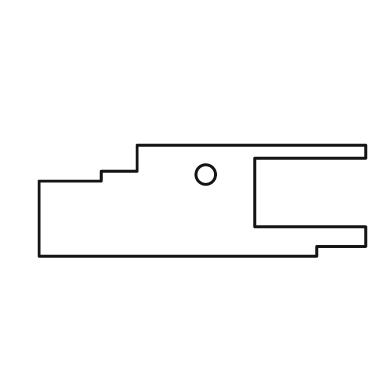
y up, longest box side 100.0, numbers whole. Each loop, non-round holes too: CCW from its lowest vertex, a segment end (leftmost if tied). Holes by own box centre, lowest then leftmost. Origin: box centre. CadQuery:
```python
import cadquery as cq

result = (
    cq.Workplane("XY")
    .moveTo(-50.0, -17.0)
    .lineTo(35.0, -17.0)
    .lineTo(35.0, -14.0)
    .lineTo(50.0, -14.0)
    .lineTo(50.0, -8.0)
    .lineTo(16.0, -8.0)
    .lineTo(16.0, 13.0)
    .lineTo(50.0, 13.0)
    .lineTo(50.0, 17.0)
    .lineTo(-20.0, 17.0)
    .lineTo(-20.0, 9.0)
    .lineTo(-31.0, 9.0)
    .lineTo(-31.0, 6.0)
    .lineTo(-50.0, 6.0)
    .close()
    .moveTo(1.0, 8.0)
    .circle(3.0)
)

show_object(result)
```